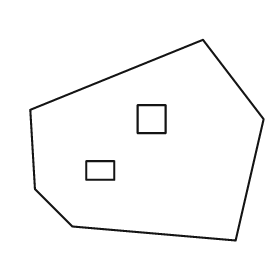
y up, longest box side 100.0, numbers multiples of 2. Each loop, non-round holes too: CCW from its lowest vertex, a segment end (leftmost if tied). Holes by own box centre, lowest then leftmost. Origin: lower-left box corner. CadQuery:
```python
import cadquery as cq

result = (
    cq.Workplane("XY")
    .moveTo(88.0, 0.0)
    .lineTo(100.0, 52.0)
    .lineTo(74.0, 86.0)
    .lineTo(0.0, 56.0)
    .lineTo(2.0, 22.0)
    .lineTo(18.0, 6.0)
    .close()
    .moveTo(24.0, 26.0)
    .lineTo(36.0, 26.0)
    .lineTo(36.0, 34.0)
    .lineTo(24.0, 34.0)
    .close()
    .moveTo(46.0, 46.0)
    .lineTo(58.0, 46.0)
    .lineTo(58.0, 58.0)
    .lineTo(46.0, 58.0)
    .close()
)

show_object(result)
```